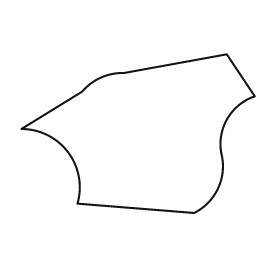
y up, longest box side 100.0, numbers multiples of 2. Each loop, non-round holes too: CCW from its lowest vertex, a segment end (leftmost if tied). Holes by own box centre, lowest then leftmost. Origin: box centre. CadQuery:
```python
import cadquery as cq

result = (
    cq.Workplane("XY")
    .moveTo(24.0, -34.0)
    .threePointArc((34.0, -24.0), (36.0, -10.0))
    .threePointArc((38.0, 6.0), (50.0, 16.0))
    .lineTo(38.0, 34.0)
    .lineTo(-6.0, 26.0)
    .threePointArc((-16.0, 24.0), (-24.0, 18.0))
    .lineTo(-50.0, 2.0)
    .threePointArc((-30.0, -8.0), (-26.0, -30.0))
    .close()
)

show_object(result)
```